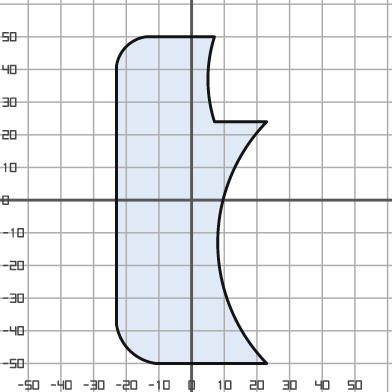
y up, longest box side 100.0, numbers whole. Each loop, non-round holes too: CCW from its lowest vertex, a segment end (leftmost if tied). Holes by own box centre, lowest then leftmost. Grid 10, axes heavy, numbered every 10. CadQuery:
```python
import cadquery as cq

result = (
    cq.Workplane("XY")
    .moveTo(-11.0, -50.0)
    .lineTo(23.0, -50.0)
    .threePointArc((8.0, -13.0), (23.0, 24.0))
    .lineTo(7.0, 24.0)
    .threePointArc((5.0, 37.0), (7.0, 50.0))
    .lineTo(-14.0, 50.0)
    .threePointArc((-20.0, 47.0), (-23.0, 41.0))
    .lineTo(-23.0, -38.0)
    .threePointArc((-19.0, -46.0), (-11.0, -50.0))
    .close()
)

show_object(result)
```